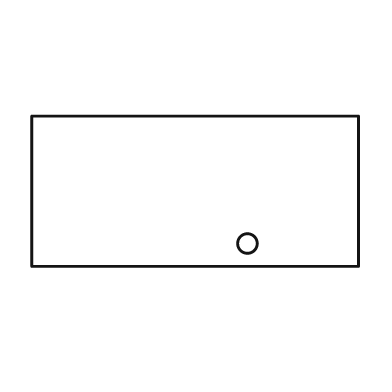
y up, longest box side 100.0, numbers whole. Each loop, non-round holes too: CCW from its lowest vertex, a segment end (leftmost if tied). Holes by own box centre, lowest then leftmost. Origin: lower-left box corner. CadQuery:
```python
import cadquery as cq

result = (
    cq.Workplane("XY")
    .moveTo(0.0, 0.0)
    .lineTo(100.0, 0.0)
    .lineTo(100.0, 46.0)
    .lineTo(0.0, 46.0)
    .close()
    .moveTo(66.0, 7.0)
    .circle(3.0)
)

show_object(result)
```